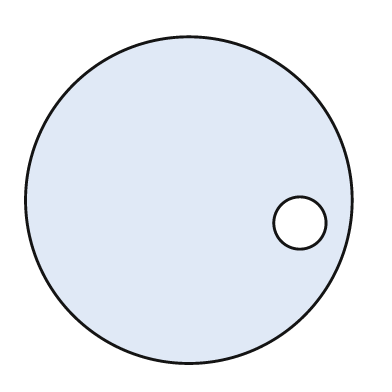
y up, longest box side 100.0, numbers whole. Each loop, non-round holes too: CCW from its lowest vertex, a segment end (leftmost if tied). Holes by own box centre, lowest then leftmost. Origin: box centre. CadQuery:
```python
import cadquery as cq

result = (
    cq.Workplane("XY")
    .moveTo(0.0, 0.0)
    .circle(50.0)
    .moveTo(34.0, -7.0)
    .circle(8.0)
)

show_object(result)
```